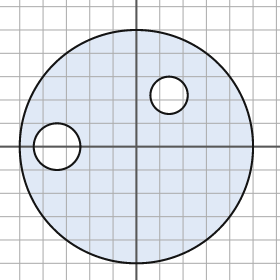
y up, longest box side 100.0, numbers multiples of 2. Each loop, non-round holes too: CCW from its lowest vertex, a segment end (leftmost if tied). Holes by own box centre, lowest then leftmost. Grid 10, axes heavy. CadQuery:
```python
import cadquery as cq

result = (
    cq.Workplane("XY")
    .moveTo(0.0, 0.0)
    .circle(50.0)
    .moveTo(-34.0, 0.0)
    .circle(10.0)
    .moveTo(14.0, 22.0)
    .circle(8.0)
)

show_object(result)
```